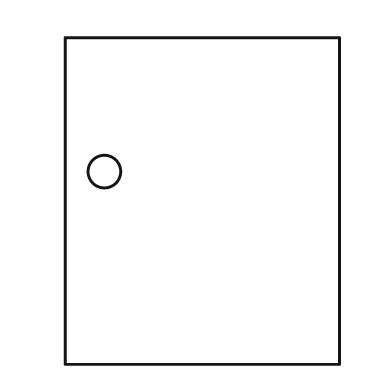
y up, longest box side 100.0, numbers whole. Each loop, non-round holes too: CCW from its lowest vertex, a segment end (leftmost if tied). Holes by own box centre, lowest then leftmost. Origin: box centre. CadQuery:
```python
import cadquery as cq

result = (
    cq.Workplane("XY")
    .moveTo(-42.0, -50.0)
    .lineTo(42.0, -50.0)
    .lineTo(42.0, 50.0)
    .lineTo(-42.0, 50.0)
    .close()
    .moveTo(-30.0, 9.0)
    .circle(5.0)
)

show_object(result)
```